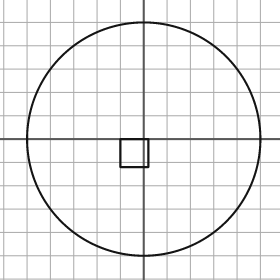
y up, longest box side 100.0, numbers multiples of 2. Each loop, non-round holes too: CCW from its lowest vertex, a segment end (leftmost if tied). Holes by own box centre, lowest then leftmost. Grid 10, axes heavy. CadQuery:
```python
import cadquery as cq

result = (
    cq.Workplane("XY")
    .moveTo(0.0, 0.0)
    .circle(50.0)
    .moveTo(-10.0, -12.0)
    .lineTo(2.0, -12.0)
    .lineTo(2.0, 0.0)
    .lineTo(-10.0, 0.0)
    .close()
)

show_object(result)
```